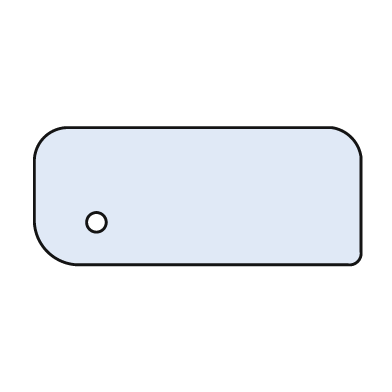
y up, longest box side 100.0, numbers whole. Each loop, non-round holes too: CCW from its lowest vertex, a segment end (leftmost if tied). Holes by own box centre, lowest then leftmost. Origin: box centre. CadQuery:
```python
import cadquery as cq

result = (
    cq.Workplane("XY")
    .moveTo(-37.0, -21.0)
    .lineTo(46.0, -21.0)
    .threePointArc((49.0, -20.0), (50.0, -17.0))
    .lineTo(50.0, 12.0)
    .threePointArc((47.0, 18.0), (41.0, 21.0))
    .lineTo(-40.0, 21.0)
    .threePointArc((-47.0, 18.0), (-50.0, 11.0))
    .lineTo(-50.0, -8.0)
    .threePointArc((-46.0, -17.0), (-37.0, -21.0))
    .close()
    .moveTo(-31.0, -8.0)
    .circle(3.0)
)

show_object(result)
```